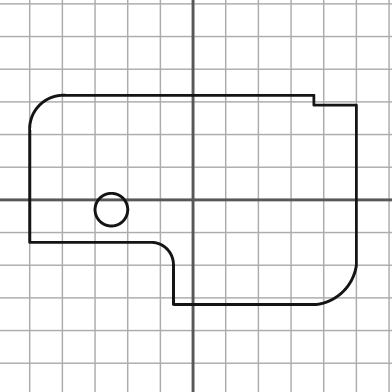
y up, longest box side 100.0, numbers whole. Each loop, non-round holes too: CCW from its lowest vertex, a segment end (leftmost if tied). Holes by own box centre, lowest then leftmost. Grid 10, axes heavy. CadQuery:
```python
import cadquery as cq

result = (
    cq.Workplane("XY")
    .moveTo(-6.0, -32.0)
    .lineTo(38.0, -32.0)
    .threePointArc((46.0, -28.0), (50.0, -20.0))
    .lineTo(50.0, 29.0)
    .lineTo(37.0, 29.0)
    .lineTo(37.0, 32.0)
    .lineTo(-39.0, 32.0)
    .threePointArc((-47.0, 29.0), (-50.0, 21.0))
    .lineTo(-50.0, -13.0)
    .lineTo(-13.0, -13.0)
    .threePointArc((-8.0, -15.0), (-6.0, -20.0))
    .close()
    .moveTo(-25.0, -3.0)
    .circle(5.0)
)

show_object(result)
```